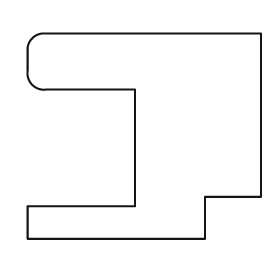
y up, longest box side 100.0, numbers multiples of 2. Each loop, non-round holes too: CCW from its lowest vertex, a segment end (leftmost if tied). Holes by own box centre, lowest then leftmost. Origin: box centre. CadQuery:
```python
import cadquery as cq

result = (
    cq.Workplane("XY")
    .moveTo(-50.0, -44.0)
    .lineTo(26.0, -44.0)
    .lineTo(26.0, -26.0)
    .lineTo(50.0, -26.0)
    .lineTo(50.0, 44.0)
    .lineTo(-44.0, 44.0)
    .threePointArc((-48.0, 42.0), (-50.0, 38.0))
    .lineTo(-50.0, 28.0)
    .threePointArc((-48.0, 22.0), (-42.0, 20.0))
    .lineTo(-4.0, 20.0)
    .lineTo(-4.0, -30.0)
    .lineTo(-50.0, -30.0)
    .close()
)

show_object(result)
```